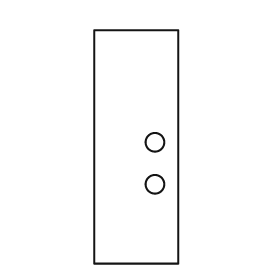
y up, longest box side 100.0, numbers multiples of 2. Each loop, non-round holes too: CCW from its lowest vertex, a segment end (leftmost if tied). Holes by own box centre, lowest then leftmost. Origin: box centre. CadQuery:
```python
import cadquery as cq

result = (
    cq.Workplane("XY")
    .moveTo(-18.0, -50.0)
    .lineTo(18.0, -50.0)
    .lineTo(18.0, 50.0)
    .lineTo(-18.0, 50.0)
    .close()
    .moveTo(8.0, -16.0)
    .circle(4.0)
    .moveTo(8.0, 2.0)
    .circle(4.0)
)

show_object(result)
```